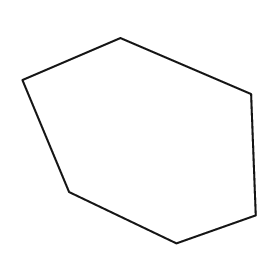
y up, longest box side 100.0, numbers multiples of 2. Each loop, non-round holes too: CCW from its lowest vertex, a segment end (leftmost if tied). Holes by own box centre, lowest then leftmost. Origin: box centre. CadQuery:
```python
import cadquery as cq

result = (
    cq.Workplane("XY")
    .moveTo(16.0, -44.0)
    .lineTo(50.0, -32.0)
    .lineTo(48.0, 20.0)
    .lineTo(-8.0, 44.0)
    .lineTo(-50.0, 26.0)
    .lineTo(-30.0, -22.0)
    .close()
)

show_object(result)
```